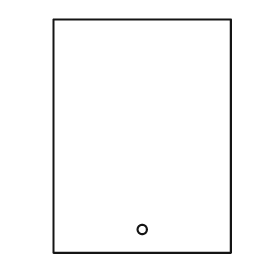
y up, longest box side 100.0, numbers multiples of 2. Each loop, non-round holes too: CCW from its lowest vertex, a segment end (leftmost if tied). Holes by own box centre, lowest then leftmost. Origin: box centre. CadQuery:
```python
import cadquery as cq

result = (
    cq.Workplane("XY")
    .moveTo(-38.0, -50.0)
    .lineTo(38.0, -50.0)
    .lineTo(38.0, 50.0)
    .lineTo(-38.0, 50.0)
    .close()
    .moveTo(0.0, -40.0)
    .circle(2.0)
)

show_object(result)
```